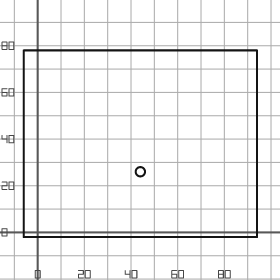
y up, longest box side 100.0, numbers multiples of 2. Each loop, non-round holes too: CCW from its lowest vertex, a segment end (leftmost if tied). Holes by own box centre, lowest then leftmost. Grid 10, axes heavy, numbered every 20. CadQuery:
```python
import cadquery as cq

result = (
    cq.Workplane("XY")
    .moveTo(-6.0, -2.0)
    .lineTo(94.0, -2.0)
    .lineTo(94.0, 78.0)
    .lineTo(-6.0, 78.0)
    .close()
    .moveTo(44.0, 26.0)
    .circle(2.0)
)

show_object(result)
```